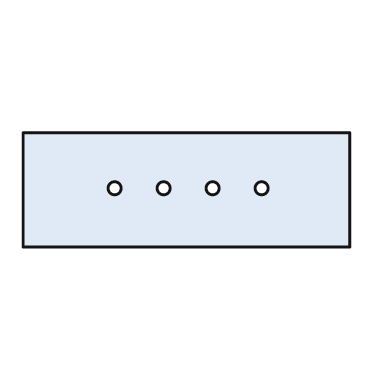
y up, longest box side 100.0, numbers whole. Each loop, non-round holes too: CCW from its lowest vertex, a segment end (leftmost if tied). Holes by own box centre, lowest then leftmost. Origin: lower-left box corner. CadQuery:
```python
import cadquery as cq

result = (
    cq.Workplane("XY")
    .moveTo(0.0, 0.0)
    .lineTo(100.0, 0.0)
    .lineTo(100.0, 35.0)
    .lineTo(0.0, 35.0)
    .close()
    .moveTo(28.0, 18.0)
    .circle(2.0)
    .moveTo(43.0, 18.0)
    .circle(2.0)
    .moveTo(58.0, 18.0)
    .circle(2.0)
    .moveTo(73.0, 18.0)
    .circle(2.0)
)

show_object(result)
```